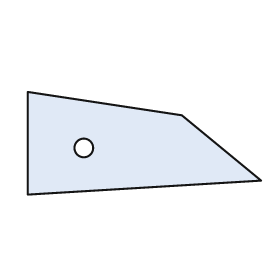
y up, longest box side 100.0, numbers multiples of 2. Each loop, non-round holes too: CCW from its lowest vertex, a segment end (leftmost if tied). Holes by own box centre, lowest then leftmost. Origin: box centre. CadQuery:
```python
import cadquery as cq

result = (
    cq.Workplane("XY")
    .moveTo(-50.0, -22.0)
    .lineTo(50.0, -16.0)
    .lineTo(16.0, 12.0)
    .lineTo(-50.0, 22.0)
    .close()
    .moveTo(-26.0, -2.0)
    .circle(4.0)
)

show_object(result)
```